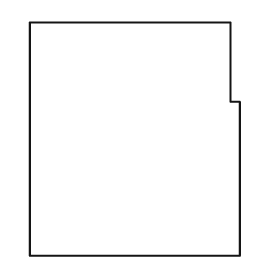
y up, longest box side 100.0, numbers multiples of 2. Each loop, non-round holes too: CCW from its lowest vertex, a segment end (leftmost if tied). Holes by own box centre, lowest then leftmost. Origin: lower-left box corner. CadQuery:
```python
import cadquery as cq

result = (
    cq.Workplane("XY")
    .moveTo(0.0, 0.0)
    .lineTo(90.0, 0.0)
    .lineTo(90.0, 66.0)
    .lineTo(86.0, 66.0)
    .lineTo(86.0, 100.0)
    .lineTo(0.0, 100.0)
    .close()
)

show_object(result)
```